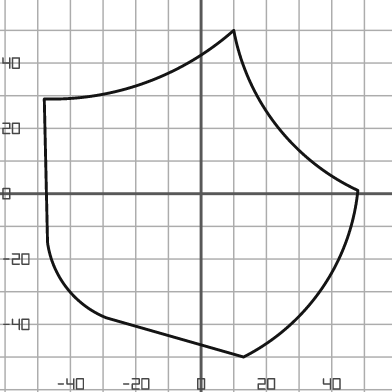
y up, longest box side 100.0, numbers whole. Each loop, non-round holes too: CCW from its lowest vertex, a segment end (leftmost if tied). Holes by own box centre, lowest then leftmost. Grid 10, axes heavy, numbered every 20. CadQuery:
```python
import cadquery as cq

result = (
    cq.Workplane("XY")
    .moveTo(13.0, -50.0)
    .threePointArc((37.0, -29.0), (48.0, 1.0))
    .threePointArc((23.0, 21.0), (10.0, 50.0))
    .threePointArc((-17.0, 34.0), (-48.0, 29.0))
    .lineTo(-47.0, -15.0)
    .threePointArc((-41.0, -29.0), (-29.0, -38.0))
    .close()
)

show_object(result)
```